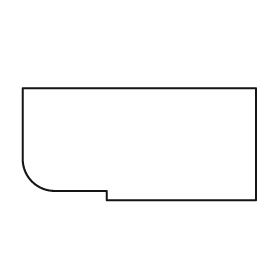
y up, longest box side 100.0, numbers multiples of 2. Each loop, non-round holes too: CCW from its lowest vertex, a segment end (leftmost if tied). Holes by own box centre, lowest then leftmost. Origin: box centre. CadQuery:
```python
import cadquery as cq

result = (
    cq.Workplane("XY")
    .moveTo(-14.0, -24.0)
    .lineTo(50.0, -24.0)
    .lineTo(50.0, 24.0)
    .lineTo(-50.0, 24.0)
    .lineTo(-50.0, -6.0)
    .threePointArc((-46.0, -16.0), (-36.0, -20.0))
    .lineTo(-14.0, -20.0)
    .close()
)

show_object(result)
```